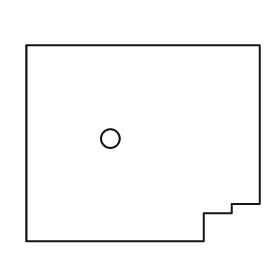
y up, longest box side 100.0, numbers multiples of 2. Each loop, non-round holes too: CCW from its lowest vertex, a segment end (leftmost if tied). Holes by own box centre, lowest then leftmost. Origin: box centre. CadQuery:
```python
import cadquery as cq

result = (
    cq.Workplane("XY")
    .moveTo(-50.0, -42.0)
    .lineTo(26.0, -42.0)
    .lineTo(26.0, -30.0)
    .lineTo(38.0, -30.0)
    .lineTo(38.0, -26.0)
    .lineTo(50.0, -26.0)
    .lineTo(50.0, 42.0)
    .lineTo(-50.0, 42.0)
    .close()
    .moveTo(-14.0, 2.0)
    .circle(4.0)
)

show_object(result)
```